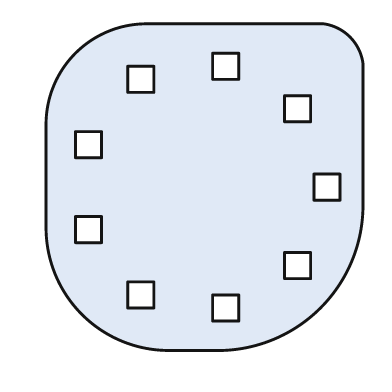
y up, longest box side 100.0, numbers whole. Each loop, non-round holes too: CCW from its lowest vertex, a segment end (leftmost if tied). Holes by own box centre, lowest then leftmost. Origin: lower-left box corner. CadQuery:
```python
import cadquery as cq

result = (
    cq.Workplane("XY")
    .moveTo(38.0, 0.0)
    .lineTo(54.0, 0.0)
    .threePointArc((84.0, 13.0), (97.0, 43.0))
    .lineTo(97.0, 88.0)
    .threePointArc((93.0, 96.0), (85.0, 100.0))
    .lineTo(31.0, 100.0)
    .threePointArc((9.0, 91.0), (0.0, 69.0))
    .lineTo(0.0, 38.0)
    .threePointArc((11.0, 11.0), (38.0, 0.0))
    .close()
    .moveTo(51.0, 9.0)
    .lineTo(59.0, 9.0)
    .lineTo(59.0, 17.0)
    .lineTo(51.0, 17.0)
    .close()
    .moveTo(25.0, 13.0)
    .lineTo(33.0, 13.0)
    .lineTo(33.0, 21.0)
    .lineTo(25.0, 21.0)
    .close()
    .moveTo(73.0, 22.0)
    .lineTo(81.0, 22.0)
    .lineTo(81.0, 30.0)
    .lineTo(73.0, 30.0)
    .close()
    .moveTo(9.0, 33.0)
    .lineTo(17.0, 33.0)
    .lineTo(17.0, 41.0)
    .lineTo(9.0, 41.0)
    .close()
    .moveTo(82.0, 46.0)
    .lineTo(90.0, 46.0)
    .lineTo(90.0, 54.0)
    .lineTo(82.0, 54.0)
    .close()
    .moveTo(9.0, 59.0)
    .lineTo(17.0, 59.0)
    .lineTo(17.0, 67.0)
    .lineTo(9.0, 67.0)
    .close()
    .moveTo(73.0, 70.0)
    .lineTo(81.0, 70.0)
    .lineTo(81.0, 78.0)
    .lineTo(73.0, 78.0)
    .close()
    .moveTo(25.0, 79.0)
    .lineTo(33.0, 79.0)
    .lineTo(33.0, 87.0)
    .lineTo(25.0, 87.0)
    .close()
    .moveTo(51.0, 83.0)
    .lineTo(59.0, 83.0)
    .lineTo(59.0, 91.0)
    .lineTo(51.0, 91.0)
    .close()
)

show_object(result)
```